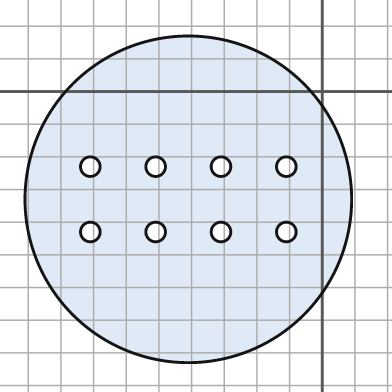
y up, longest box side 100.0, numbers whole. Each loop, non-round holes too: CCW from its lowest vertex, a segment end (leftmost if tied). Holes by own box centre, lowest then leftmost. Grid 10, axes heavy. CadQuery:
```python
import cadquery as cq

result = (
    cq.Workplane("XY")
    .moveTo(-41.0, -33.0)
    .circle(50.0)
    .moveTo(-71.0, -43.0)
    .circle(3.0)
    .moveTo(-51.0, -43.0)
    .circle(3.0)
    .moveTo(-31.0, -43.0)
    .circle(3.0)
    .moveTo(-11.0, -43.0)
    .circle(3.0)
    .moveTo(-71.0, -23.0)
    .circle(3.0)
    .moveTo(-51.0, -23.0)
    .circle(3.0)
    .moveTo(-31.0, -23.0)
    .circle(3.0)
    .moveTo(-11.0, -23.0)
    .circle(3.0)
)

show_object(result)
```